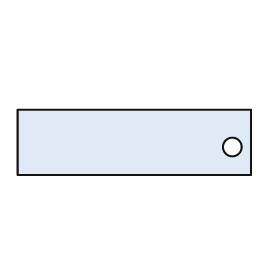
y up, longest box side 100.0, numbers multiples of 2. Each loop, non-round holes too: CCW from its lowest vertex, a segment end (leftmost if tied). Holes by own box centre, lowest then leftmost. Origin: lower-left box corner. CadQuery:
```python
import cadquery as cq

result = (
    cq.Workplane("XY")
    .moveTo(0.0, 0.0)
    .lineTo(100.0, 0.0)
    .lineTo(100.0, 28.0)
    .lineTo(0.0, 28.0)
    .close()
    .moveTo(92.0, 12.0)
    .circle(4.0)
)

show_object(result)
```